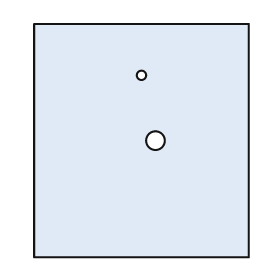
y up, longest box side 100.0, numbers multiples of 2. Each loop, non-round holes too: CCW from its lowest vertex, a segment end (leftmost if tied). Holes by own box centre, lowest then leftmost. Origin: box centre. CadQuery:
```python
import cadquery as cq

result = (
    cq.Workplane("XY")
    .moveTo(-46.0, -50.0)
    .lineTo(46.0, -50.0)
    .lineTo(46.0, 50.0)
    .lineTo(-46.0, 50.0)
    .close()
    .moveTo(6.0, 0.0)
    .circle(4.0)
    .moveTo(0.0, 28.0)
    .circle(2.0)
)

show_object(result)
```